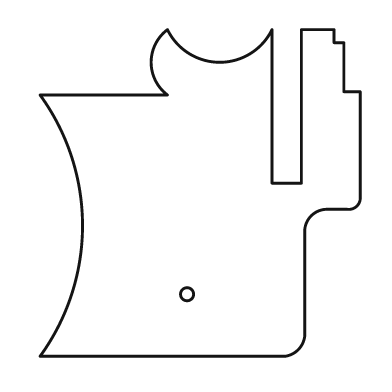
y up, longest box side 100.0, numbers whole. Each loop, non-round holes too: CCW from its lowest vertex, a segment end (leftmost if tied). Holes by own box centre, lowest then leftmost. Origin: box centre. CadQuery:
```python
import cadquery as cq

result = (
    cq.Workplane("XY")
    .moveTo(-49.0, -50.0)
    .lineTo(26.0, -50.0)
    .threePointArc((30.0, -48.0), (32.0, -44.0))
    .lineTo(32.0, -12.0)
    .threePointArc((34.0, -7.0), (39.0, -5.0))
    .lineTo(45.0, -5.0)
    .threePointArc((48.0, -4.0), (49.0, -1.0))
    .lineTo(49.0, 31.0)
    .lineTo(44.0, 31.0)
    .lineTo(44.0, 46.0)
    .lineTo(41.0, 46.0)
    .lineTo(41.0, 50.0)
    .lineTo(31.0, 50.0)
    .lineTo(31.0, 3.0)
    .lineTo(22.0, 3.0)
    .lineTo(22.0, 50.0)
    .threePointArc((6.0, 40.0), (-10.0, 50.0))
    .threePointArc((-15.0, 40.0), (-10.0, 30.0))
    .lineTo(-49.0, 30.0)
    .threePointArc((-36.0, -10.0), (-49.0, -50.0))
    .close()
    .moveTo(-4.0, -31.0)
    .circle(2.0)
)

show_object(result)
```